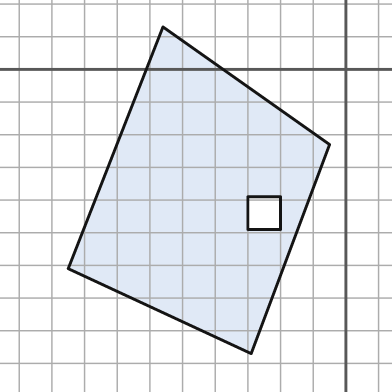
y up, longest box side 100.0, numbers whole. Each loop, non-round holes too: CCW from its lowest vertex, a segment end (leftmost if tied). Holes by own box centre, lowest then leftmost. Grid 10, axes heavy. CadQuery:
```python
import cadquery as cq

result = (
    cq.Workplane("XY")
    .moveTo(-29.0, -87.0)
    .lineTo(-5.0, -23.0)
    .lineTo(-56.0, 13.0)
    .lineTo(-85.0, -61.0)
    .close()
    .moveTo(-30.0, -49.0)
    .lineTo(-20.0, -49.0)
    .lineTo(-20.0, -39.0)
    .lineTo(-30.0, -39.0)
    .close()
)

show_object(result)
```